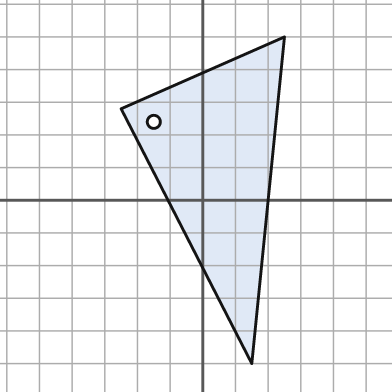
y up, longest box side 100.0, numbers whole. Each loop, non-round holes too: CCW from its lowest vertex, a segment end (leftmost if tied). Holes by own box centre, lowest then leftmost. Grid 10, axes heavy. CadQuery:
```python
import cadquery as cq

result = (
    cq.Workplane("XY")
    .moveTo(15.0, -50.0)
    .lineTo(25.0, 50.0)
    .lineTo(-25.0, 28.0)
    .close()
    .moveTo(-15.0, 24.0)
    .circle(2.0)
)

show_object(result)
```